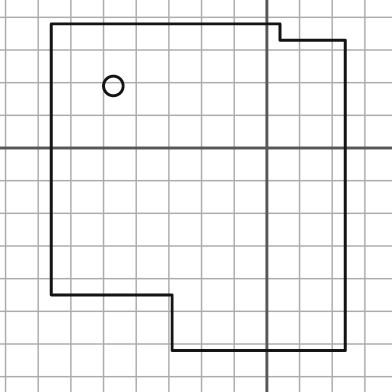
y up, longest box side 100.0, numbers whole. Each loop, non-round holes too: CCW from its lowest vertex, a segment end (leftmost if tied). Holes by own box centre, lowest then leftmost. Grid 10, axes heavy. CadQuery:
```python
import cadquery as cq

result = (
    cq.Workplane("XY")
    .moveTo(-29.0, -62.0)
    .lineTo(24.0, -62.0)
    .lineTo(24.0, 33.0)
    .lineTo(4.0, 33.0)
    .lineTo(4.0, 38.0)
    .lineTo(-66.0, 38.0)
    .lineTo(-66.0, -45.0)
    .lineTo(-29.0, -45.0)
    .close()
    .moveTo(-47.0, 19.0)
    .circle(3.0)
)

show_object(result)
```